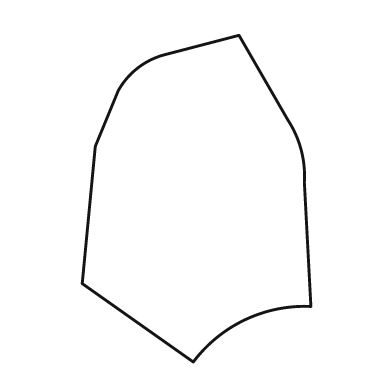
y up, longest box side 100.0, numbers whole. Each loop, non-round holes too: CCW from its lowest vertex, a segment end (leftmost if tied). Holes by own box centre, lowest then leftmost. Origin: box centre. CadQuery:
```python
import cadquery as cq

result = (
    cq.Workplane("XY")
    .moveTo(-1.0, -50.0)
    .threePointArc((15.0, -37.0), (35.0, -33.0))
    .lineTo(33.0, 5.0)
    .threePointArc((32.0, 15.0), (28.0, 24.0))
    .lineTo(13.0, 50.0)
    .lineTo(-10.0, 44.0)
    .threePointArc((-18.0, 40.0), (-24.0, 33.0))
    .lineTo(-31.0, 16.0)
    .lineTo(-35.0, -26.0)
    .close()
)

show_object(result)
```